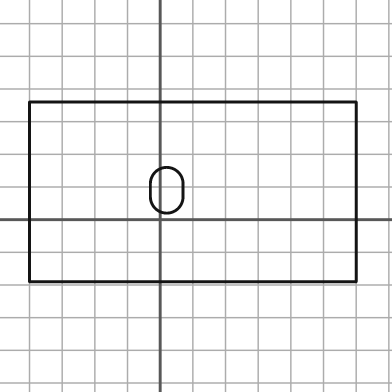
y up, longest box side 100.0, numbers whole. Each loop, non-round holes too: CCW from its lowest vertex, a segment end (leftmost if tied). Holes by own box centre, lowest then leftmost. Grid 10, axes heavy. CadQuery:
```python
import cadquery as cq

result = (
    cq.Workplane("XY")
    .moveTo(-40.0, -19.0)
    .lineTo(60.0, -19.0)
    .lineTo(60.0, 36.0)
    .lineTo(-40.0, 36.0)
    .close()
    .moveTo(-3.0, 7.0)
    .threePointArc((2.0, 2.0), (7.0, 7.0))
    .lineTo(7.0, 11.0)
    .threePointArc((2.0, 16.0), (-3.0, 11.0))
    .close()
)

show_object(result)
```